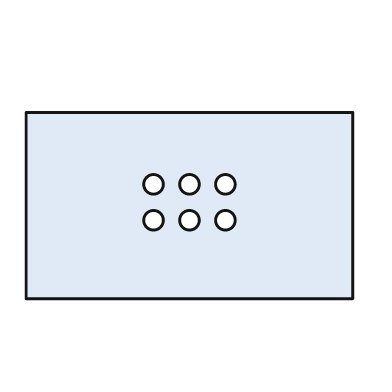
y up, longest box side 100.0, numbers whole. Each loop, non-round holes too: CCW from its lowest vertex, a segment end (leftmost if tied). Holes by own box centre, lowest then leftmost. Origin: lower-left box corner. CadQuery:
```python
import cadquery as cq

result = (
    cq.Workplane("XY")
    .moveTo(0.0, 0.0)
    .lineTo(100.0, 0.0)
    .lineTo(100.0, 57.0)
    .lineTo(0.0, 57.0)
    .close()
    .moveTo(39.0, 24.0)
    .circle(3.0)
    .moveTo(50.0, 24.0)
    .circle(3.0)
    .moveTo(61.0, 24.0)
    .circle(3.0)
    .moveTo(39.0, 35.0)
    .circle(3.0)
    .moveTo(50.0, 35.0)
    .circle(3.0)
    .moveTo(61.0, 35.0)
    .circle(3.0)
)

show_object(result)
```